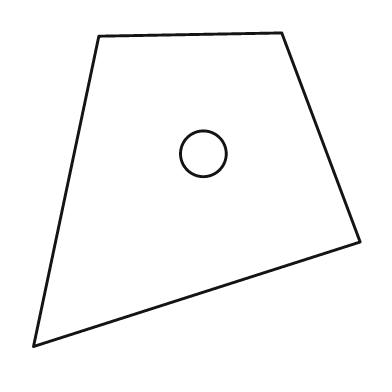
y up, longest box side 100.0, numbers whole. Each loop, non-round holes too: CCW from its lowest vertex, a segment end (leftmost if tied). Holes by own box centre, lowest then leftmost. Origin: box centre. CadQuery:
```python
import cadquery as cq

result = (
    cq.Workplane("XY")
    .moveTo(-50.0, -48.0)
    .lineTo(50.0, -16.0)
    .lineTo(26.0, 48.0)
    .lineTo(-30.0, 47.0)
    .close()
    .moveTo(2.0, 11.0)
    .circle(7.0)
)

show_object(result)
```